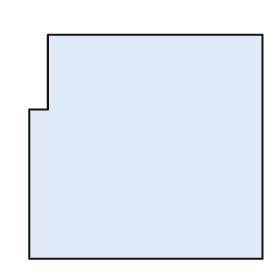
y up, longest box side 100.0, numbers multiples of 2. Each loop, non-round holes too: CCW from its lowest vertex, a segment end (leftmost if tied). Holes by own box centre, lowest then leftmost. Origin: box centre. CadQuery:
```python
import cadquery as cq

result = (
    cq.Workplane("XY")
    .moveTo(-50.0, -48.0)
    .lineTo(50.0, -48.0)
    .lineTo(50.0, 48.0)
    .lineTo(-42.0, 48.0)
    .lineTo(-42.0, 16.0)
    .lineTo(-50.0, 16.0)
    .close()
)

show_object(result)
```